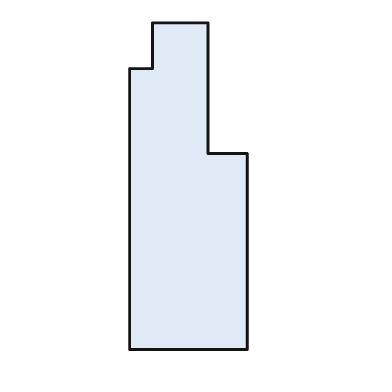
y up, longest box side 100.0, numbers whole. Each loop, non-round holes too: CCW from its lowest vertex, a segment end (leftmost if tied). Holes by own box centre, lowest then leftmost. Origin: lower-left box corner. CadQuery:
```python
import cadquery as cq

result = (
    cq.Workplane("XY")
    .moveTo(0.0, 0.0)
    .lineTo(36.0, 0.0)
    .lineTo(36.0, 60.0)
    .lineTo(24.0, 60.0)
    .lineTo(24.0, 100.0)
    .lineTo(7.0, 100.0)
    .lineTo(7.0, 86.0)
    .lineTo(0.0, 86.0)
    .close()
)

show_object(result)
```